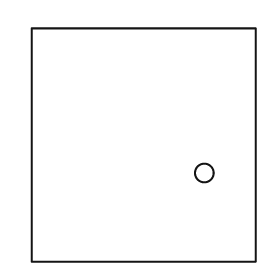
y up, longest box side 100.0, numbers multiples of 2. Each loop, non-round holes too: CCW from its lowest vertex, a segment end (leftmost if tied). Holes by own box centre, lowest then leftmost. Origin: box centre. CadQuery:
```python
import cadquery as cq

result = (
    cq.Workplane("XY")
    .moveTo(-48.0, -50.0)
    .lineTo(48.0, -50.0)
    .lineTo(48.0, 50.0)
    .lineTo(-48.0, 50.0)
    .close()
    .moveTo(26.0, -12.0)
    .circle(4.0)
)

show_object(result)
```